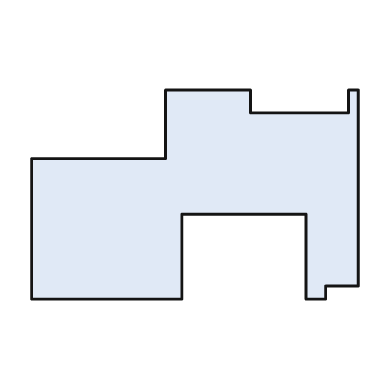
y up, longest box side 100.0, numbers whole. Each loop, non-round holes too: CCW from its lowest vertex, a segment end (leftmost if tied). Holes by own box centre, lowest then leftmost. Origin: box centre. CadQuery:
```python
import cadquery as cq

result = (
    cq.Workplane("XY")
    .moveTo(-50.0, -32.0)
    .lineTo(-4.0, -32.0)
    .lineTo(-4.0, -6.0)
    .lineTo(34.0, -6.0)
    .lineTo(34.0, -32.0)
    .lineTo(40.0, -32.0)
    .lineTo(40.0, -28.0)
    .lineTo(50.0, -28.0)
    .lineTo(50.0, 32.0)
    .lineTo(47.0, 32.0)
    .lineTo(47.0, 25.0)
    .lineTo(17.0, 25.0)
    .lineTo(17.0, 32.0)
    .lineTo(-9.0, 32.0)
    .lineTo(-9.0, 11.0)
    .lineTo(-50.0, 11.0)
    .close()
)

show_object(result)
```